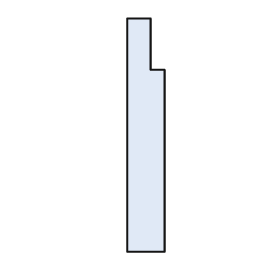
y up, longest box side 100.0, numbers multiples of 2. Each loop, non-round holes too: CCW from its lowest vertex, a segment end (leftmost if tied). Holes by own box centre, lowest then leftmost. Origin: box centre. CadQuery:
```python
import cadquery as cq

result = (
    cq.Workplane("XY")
    .moveTo(-8.0, -50.0)
    .lineTo(8.0, -50.0)
    .lineTo(8.0, 28.0)
    .lineTo(2.0, 28.0)
    .lineTo(2.0, 50.0)
    .lineTo(-8.0, 50.0)
    .close()
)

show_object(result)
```